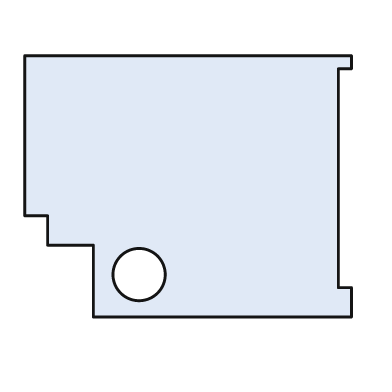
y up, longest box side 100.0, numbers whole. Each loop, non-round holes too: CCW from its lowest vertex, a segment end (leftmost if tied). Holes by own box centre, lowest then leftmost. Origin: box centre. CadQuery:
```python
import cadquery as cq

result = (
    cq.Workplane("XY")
    .moveTo(-29.0, -40.0)
    .lineTo(50.0, -40.0)
    .lineTo(50.0, -31.0)
    .lineTo(46.0, -31.0)
    .lineTo(46.0, 36.0)
    .lineTo(50.0, 36.0)
    .lineTo(50.0, 40.0)
    .lineTo(-50.0, 40.0)
    .lineTo(-50.0, -9.0)
    .lineTo(-43.0, -9.0)
    .lineTo(-43.0, -18.0)
    .lineTo(-29.0, -18.0)
    .close()
    .moveTo(-15.0, -27.0)
    .circle(8.0)
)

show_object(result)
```